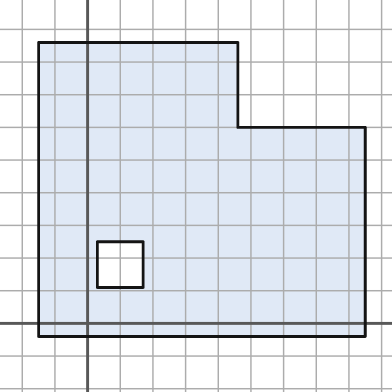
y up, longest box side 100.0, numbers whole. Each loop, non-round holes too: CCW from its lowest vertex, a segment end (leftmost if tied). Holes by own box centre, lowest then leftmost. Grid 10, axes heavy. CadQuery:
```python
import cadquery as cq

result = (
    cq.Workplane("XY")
    .moveTo(-15.0, -4.0)
    .lineTo(85.0, -4.0)
    .lineTo(85.0, 60.0)
    .lineTo(46.0, 60.0)
    .lineTo(46.0, 86.0)
    .lineTo(-15.0, 86.0)
    .close()
    .moveTo(3.0, 11.0)
    .lineTo(17.0, 11.0)
    .lineTo(17.0, 25.0)
    .lineTo(3.0, 25.0)
    .close()
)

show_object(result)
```